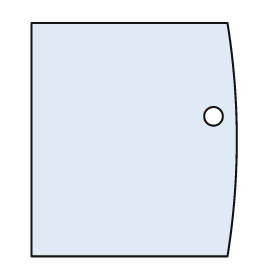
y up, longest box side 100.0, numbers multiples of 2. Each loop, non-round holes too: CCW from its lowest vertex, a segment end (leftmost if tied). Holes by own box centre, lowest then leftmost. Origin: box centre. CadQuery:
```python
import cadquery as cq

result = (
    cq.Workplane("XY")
    .moveTo(-44.0, -50.0)
    .lineTo(40.0, -50.0)
    .threePointArc((44.0, 0.0), (40.0, 50.0))
    .lineTo(-44.0, 50.0)
    .close()
    .moveTo(34.0, 10.0)
    .circle(4.0)
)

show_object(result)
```